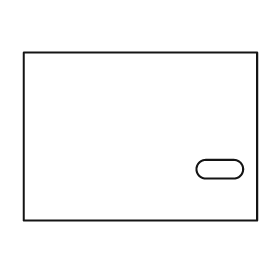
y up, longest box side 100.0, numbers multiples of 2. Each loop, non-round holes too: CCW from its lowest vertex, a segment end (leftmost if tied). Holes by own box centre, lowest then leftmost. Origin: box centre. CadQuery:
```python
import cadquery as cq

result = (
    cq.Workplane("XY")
    .moveTo(-50.0, -36.0)
    .lineTo(50.0, -36.0)
    .lineTo(50.0, 36.0)
    .lineTo(-50.0, 36.0)
    .close()
    .moveTo(28.0, -18.0)
    .lineTo(40.0, -18.0)
    .threePointArc((44.0, -14.0), (40.0, -10.0))
    .lineTo(28.0, -10.0)
    .threePointArc((24.0, -14.0), (28.0, -18.0))
    .close()
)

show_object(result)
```